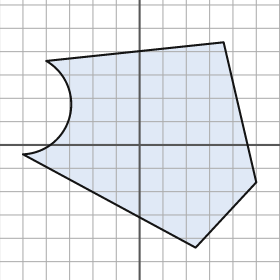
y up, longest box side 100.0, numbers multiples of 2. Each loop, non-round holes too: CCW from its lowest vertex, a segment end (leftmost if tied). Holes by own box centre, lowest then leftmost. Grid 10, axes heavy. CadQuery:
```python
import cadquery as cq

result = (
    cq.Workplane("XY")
    .moveTo(24.0, -44.0)
    .lineTo(50.0, -16.0)
    .lineTo(36.0, 44.0)
    .lineTo(-40.0, 36.0)
    .threePointArc((-30.0, 12.0), (-50.0, -4.0))
    .close()
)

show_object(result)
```